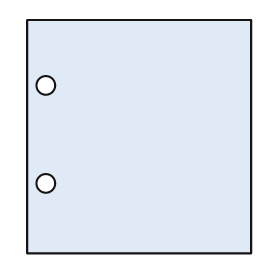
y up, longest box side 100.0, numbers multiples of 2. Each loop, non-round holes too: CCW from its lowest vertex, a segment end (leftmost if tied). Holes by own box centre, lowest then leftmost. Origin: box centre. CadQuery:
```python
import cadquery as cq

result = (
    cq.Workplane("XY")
    .moveTo(-48.0, -50.0)
    .lineTo(48.0, -50.0)
    .lineTo(48.0, 50.0)
    .lineTo(-48.0, 50.0)
    .close()
    .moveTo(-40.0, -20.0)
    .circle(4.0)
    .moveTo(-40.0, 22.0)
    .circle(4.0)
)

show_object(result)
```